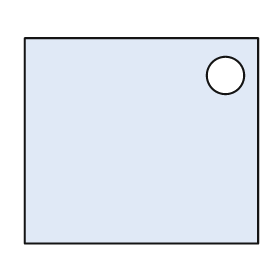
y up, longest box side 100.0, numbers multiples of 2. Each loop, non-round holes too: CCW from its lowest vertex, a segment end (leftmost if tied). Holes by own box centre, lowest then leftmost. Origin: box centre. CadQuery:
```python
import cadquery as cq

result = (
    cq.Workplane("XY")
    .moveTo(-50.0, -44.0)
    .lineTo(50.0, -44.0)
    .lineTo(50.0, 44.0)
    .lineTo(-50.0, 44.0)
    .close()
    .moveTo(36.0, 28.0)
    .circle(8.0)
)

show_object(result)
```